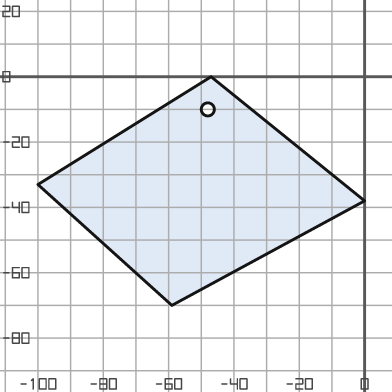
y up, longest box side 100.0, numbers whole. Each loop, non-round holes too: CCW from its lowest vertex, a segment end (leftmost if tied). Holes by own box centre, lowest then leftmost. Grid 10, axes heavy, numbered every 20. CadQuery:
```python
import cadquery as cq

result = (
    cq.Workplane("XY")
    .moveTo(-59.0, -70.0)
    .lineTo(0.0, -38.0)
    .lineTo(-47.0, 0.0)
    .lineTo(-100.0, -33.0)
    .close()
    .moveTo(-48.0, -10.0)
    .circle(2.0)
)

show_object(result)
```